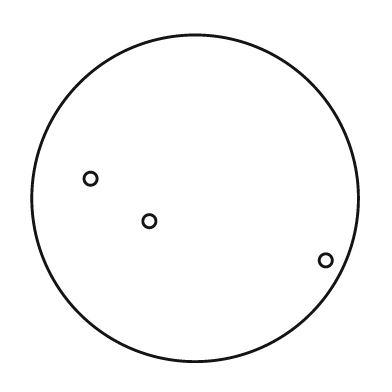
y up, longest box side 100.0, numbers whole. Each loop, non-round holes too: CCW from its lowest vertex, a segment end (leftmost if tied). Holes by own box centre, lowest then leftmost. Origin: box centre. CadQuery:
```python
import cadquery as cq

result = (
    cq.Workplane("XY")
    .moveTo(0.0, 0.0)
    .circle(50.0)
    .moveTo(40.0, -19.0)
    .circle(2.0)
    .moveTo(-14.0, -7.0)
    .circle(2.0)
    .moveTo(-32.0, 6.0)
    .circle(2.0)
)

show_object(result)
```